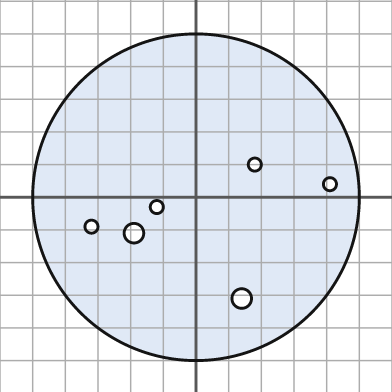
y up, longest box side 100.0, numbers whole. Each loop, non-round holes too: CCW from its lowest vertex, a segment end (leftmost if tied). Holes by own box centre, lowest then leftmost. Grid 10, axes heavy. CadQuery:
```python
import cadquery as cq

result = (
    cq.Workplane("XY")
    .moveTo(0.0, 0.0)
    .circle(50.0)
    .moveTo(14.0, -31.0)
    .circle(3.0)
    .moveTo(-19.0, -11.0)
    .circle(3.0)
    .moveTo(-32.0, -9.0)
    .circle(2.0)
    .moveTo(-12.0, -3.0)
    .circle(2.0)
    .moveTo(41.0, 4.0)
    .circle(2.0)
    .moveTo(18.0, 10.0)
    .circle(2.0)
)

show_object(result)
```